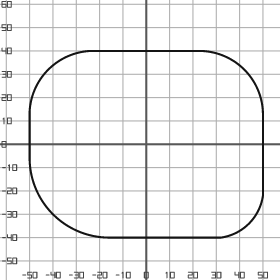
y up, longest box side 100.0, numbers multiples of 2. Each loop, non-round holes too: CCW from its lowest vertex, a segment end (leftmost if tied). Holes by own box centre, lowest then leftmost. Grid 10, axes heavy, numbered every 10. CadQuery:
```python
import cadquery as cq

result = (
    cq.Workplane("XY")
    .moveTo(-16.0, -40.0)
    .lineTo(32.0, -40.0)
    .threePointArc((44.0, -34.0), (50.0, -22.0))
    .lineTo(50.0, 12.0)
    .threePointArc((42.0, 32.0), (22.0, 40.0))
    .lineTo(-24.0, 40.0)
    .threePointArc((-42.0, 32.0), (-50.0, 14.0))
    .lineTo(-50.0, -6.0)
    .threePointArc((-40.0, -30.0), (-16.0, -40.0))
    .close()
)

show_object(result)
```